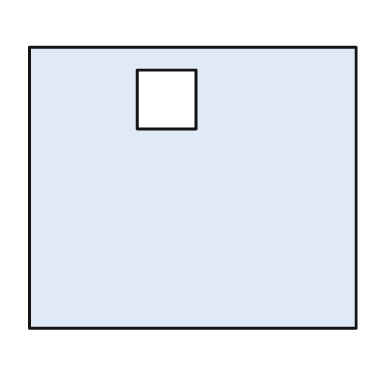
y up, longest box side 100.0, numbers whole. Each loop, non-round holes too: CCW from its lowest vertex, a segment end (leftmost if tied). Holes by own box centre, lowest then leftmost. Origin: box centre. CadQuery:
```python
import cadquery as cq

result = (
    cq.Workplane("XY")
    .moveTo(-50.0, -43.0)
    .lineTo(50.0, -43.0)
    .lineTo(50.0, 43.0)
    .lineTo(-50.0, 43.0)
    .close()
    .moveTo(-17.0, 18.0)
    .lineTo(1.0, 18.0)
    .lineTo(1.0, 36.0)
    .lineTo(-17.0, 36.0)
    .close()
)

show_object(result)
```